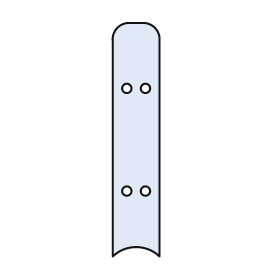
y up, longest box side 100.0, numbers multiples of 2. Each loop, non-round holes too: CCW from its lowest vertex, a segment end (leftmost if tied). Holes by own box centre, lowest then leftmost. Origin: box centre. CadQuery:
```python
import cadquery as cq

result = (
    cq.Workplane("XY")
    .moveTo(-10.0, -50.0)
    .threePointArc((0.0, -46.0), (10.0, -50.0))
    .lineTo(10.0, 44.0)
    .threePointArc((8.0, 48.0), (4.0, 50.0))
    .lineTo(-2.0, 50.0)
    .threePointArc((-8.0, 48.0), (-10.0, 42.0))
    .close()
    .moveTo(-4.0, -22.0)
    .circle(2.0)
    .moveTo(4.0, -22.0)
    .circle(2.0)
    .moveTo(-4.0, 22.0)
    .circle(2.0)
    .moveTo(4.0, 22.0)
    .circle(2.0)
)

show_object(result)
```